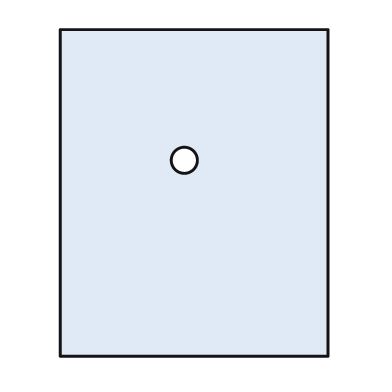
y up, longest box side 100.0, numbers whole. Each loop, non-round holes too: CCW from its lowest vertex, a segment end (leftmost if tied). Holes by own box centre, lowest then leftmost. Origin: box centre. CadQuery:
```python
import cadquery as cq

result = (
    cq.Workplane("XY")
    .moveTo(-41.0, -50.0)
    .lineTo(41.0, -50.0)
    .lineTo(41.0, 50.0)
    .lineTo(-41.0, 50.0)
    .close()
    .moveTo(-3.0, 10.0)
    .circle(4.0)
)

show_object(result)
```